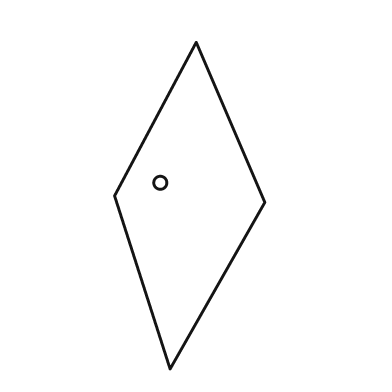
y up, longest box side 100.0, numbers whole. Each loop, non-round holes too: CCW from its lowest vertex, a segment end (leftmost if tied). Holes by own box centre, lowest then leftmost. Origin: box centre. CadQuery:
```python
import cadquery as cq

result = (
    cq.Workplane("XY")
    .moveTo(-6.0, -50.0)
    .lineTo(23.0, 1.0)
    .lineTo(2.0, 50.0)
    .lineTo(-23.0, 3.0)
    .close()
    .moveTo(-9.0, 7.0)
    .circle(2.0)
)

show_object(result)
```